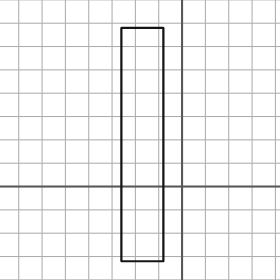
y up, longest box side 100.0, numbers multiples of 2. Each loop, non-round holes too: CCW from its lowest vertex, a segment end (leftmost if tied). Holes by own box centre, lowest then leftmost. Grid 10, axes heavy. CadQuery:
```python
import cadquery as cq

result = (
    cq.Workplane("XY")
    .moveTo(-26.0, -32.0)
    .lineTo(-8.0, -32.0)
    .lineTo(-8.0, 68.0)
    .lineTo(-26.0, 68.0)
    .close()
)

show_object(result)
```